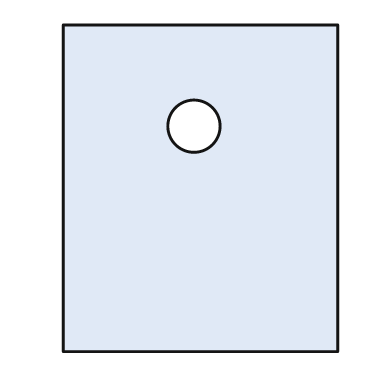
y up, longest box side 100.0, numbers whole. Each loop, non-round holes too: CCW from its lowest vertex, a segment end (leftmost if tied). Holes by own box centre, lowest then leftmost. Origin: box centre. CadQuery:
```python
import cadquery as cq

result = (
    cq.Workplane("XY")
    .moveTo(-42.0, -50.0)
    .lineTo(42.0, -50.0)
    .lineTo(42.0, 50.0)
    .lineTo(-42.0, 50.0)
    .close()
    .moveTo(-2.0, 19.0)
    .circle(8.0)
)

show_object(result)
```